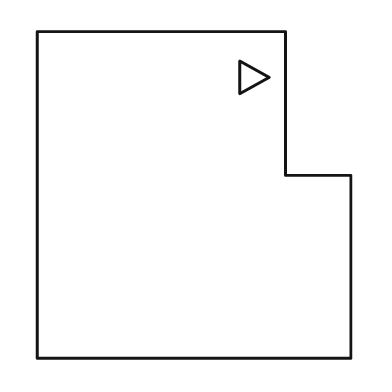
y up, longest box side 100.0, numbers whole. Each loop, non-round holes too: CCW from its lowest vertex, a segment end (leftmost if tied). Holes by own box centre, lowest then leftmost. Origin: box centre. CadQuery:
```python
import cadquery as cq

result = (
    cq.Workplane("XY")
    .moveTo(-48.0, -50.0)
    .lineTo(48.0, -50.0)
    .lineTo(48.0, 6.0)
    .lineTo(28.0, 6.0)
    .lineTo(28.0, 50.0)
    .lineTo(-48.0, 50.0)
    .close()
    .moveTo(14.0, 31.0)
    .lineTo(23.0, 36.0)
    .lineTo(14.0, 41.0)
    .close()
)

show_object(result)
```